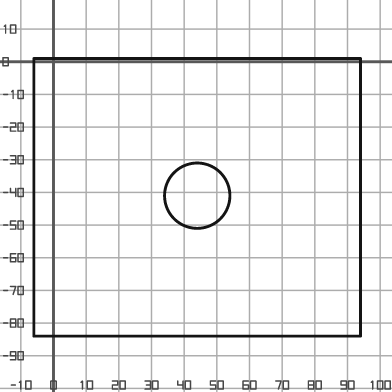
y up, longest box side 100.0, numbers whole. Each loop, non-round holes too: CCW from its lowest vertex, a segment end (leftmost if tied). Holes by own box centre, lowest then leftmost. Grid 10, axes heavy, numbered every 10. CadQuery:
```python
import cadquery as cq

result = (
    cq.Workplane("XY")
    .moveTo(-6.0, -84.0)
    .lineTo(94.0, -84.0)
    .lineTo(94.0, 1.0)
    .lineTo(-6.0, 1.0)
    .close()
    .moveTo(44.0, -41.0)
    .circle(10.0)
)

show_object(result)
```